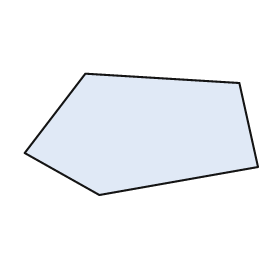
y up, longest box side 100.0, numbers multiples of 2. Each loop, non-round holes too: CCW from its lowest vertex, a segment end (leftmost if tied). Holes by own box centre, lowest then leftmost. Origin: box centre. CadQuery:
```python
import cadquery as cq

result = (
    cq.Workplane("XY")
    .moveTo(-18.0, -26.0)
    .lineTo(50.0, -14.0)
    .lineTo(42.0, 22.0)
    .lineTo(-24.0, 26.0)
    .lineTo(-50.0, -8.0)
    .close()
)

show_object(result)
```